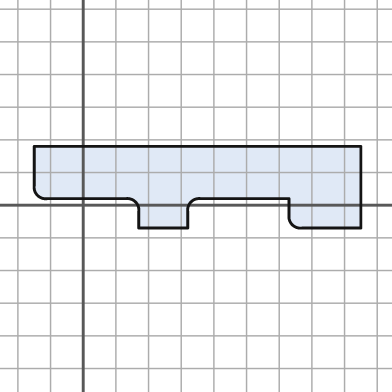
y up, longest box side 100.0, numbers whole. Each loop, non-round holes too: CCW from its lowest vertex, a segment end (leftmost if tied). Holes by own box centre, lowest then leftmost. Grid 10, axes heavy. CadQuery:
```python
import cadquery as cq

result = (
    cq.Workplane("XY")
    .moveTo(17.0, -7.0)
    .lineTo(32.0, -7.0)
    .lineTo(32.0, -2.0)
    .threePointArc((33.0, 1.0), (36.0, 2.0))
    .lineTo(63.0, 2.0)
    .lineTo(63.0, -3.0)
    .threePointArc((64.0, -6.0), (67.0, -7.0))
    .lineTo(85.0, -7.0)
    .lineTo(85.0, 18.0)
    .lineTo(-15.0, 18.0)
    .lineTo(-15.0, 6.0)
    .threePointArc((-14.0, 3.0), (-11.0, 2.0))
    .lineTo(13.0, 2.0)
    .threePointArc((16.0, 1.0), (17.0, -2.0))
    .close()
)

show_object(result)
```